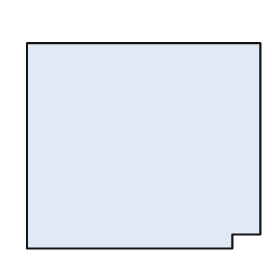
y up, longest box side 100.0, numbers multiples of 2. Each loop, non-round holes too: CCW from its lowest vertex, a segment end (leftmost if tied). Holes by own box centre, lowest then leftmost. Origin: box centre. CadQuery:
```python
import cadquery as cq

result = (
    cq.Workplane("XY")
    .moveTo(-50.0, -44.0)
    .lineTo(38.0, -44.0)
    .lineTo(38.0, -38.0)
    .lineTo(50.0, -38.0)
    .lineTo(50.0, 44.0)
    .lineTo(-50.0, 44.0)
    .close()
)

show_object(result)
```